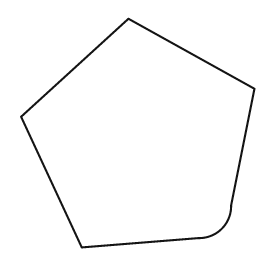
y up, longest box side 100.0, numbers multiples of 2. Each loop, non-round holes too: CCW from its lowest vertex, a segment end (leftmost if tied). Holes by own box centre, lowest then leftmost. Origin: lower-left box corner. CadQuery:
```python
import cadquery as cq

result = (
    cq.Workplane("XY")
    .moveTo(26.0, 0.0)
    .lineTo(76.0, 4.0)
    .threePointArc((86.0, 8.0), (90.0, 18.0))
    .lineTo(100.0, 68.0)
    .lineTo(46.0, 98.0)
    .lineTo(0.0, 56.0)
    .close()
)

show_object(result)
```